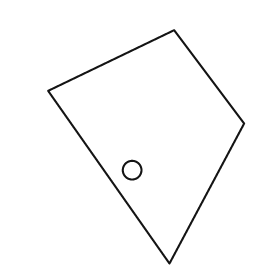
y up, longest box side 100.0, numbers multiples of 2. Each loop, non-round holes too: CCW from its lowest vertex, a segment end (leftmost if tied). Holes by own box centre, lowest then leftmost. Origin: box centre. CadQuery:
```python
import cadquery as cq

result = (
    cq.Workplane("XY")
    .moveTo(10.0, -50.0)
    .lineTo(42.0, 10.0)
    .lineTo(12.0, 50.0)
    .lineTo(-42.0, 24.0)
    .close()
    .moveTo(-6.0, -10.0)
    .circle(4.0)
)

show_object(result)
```